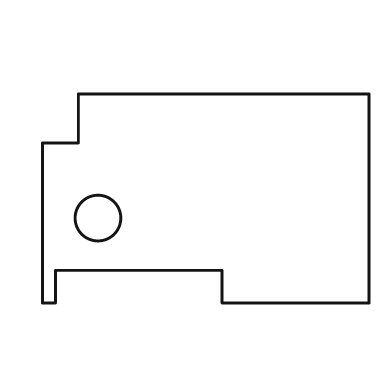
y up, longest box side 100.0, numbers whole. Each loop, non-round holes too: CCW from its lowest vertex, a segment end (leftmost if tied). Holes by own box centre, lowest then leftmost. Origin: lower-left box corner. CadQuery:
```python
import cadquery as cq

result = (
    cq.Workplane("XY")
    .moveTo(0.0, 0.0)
    .lineTo(4.0, 0.0)
    .lineTo(4.0, 10.0)
    .lineTo(55.0, 10.0)
    .lineTo(55.0, 0.0)
    .lineTo(100.0, 0.0)
    .lineTo(100.0, 64.0)
    .lineTo(11.0, 64.0)
    .lineTo(11.0, 49.0)
    .lineTo(0.0, 49.0)
    .close()
    .moveTo(17.0, 26.0)
    .circle(7.0)
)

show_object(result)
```